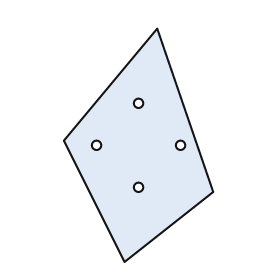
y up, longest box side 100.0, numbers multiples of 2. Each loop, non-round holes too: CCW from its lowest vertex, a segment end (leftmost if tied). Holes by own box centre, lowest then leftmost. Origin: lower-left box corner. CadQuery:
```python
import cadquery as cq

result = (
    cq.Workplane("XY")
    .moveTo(26.0, 0.0)
    .lineTo(64.0, 30.0)
    .lineTo(40.0, 100.0)
    .lineTo(0.0, 52.0)
    .close()
    .moveTo(32.0, 32.0)
    .circle(2.0)
    .moveTo(14.0, 50.0)
    .circle(2.0)
    .moveTo(50.0, 50.0)
    .circle(2.0)
    .moveTo(32.0, 68.0)
    .circle(2.0)
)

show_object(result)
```